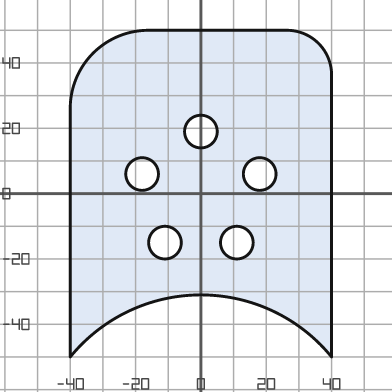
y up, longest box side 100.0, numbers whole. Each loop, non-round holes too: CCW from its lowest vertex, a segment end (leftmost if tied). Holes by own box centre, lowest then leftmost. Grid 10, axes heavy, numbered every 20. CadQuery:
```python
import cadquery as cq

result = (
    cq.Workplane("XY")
    .moveTo(-40.0, -50.0)
    .threePointArc((0.0, -31.0), (40.0, -50.0))
    .lineTo(40.0, 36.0)
    .threePointArc((36.0, 46.0), (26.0, 50.0))
    .lineTo(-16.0, 50.0)
    .threePointArc((-33.0, 43.0), (-40.0, 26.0))
    .close()
    .moveTo(-11.0, -15.0)
    .circle(5.0)
    .moveTo(11.0, -15.0)
    .circle(5.0)
    .moveTo(-18.0, 6.0)
    .circle(5.0)
    .moveTo(18.0, 6.0)
    .circle(5.0)
    .moveTo(0.0, 19.0)
    .circle(5.0)
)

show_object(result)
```